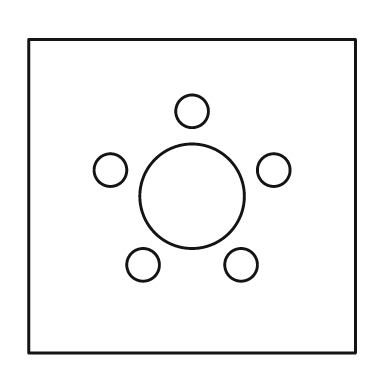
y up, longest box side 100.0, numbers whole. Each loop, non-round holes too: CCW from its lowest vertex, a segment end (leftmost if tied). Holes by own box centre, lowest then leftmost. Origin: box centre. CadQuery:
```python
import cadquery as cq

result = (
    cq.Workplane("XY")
    .moveTo(-50.0, -48.0)
    .lineTo(50.0, -48.0)
    .lineTo(50.0, 48.0)
    .lineTo(-50.0, 48.0)
    .close()
    .moveTo(-15.0, -21.0)
    .circle(5.0)
    .moveTo(15.0, -21.0)
    .circle(5.0)
    .moveTo(0.0, 0.0)
    .circle(16.0)
    .moveTo(-25.0, 8.0)
    .circle(5.0)
    .moveTo(25.0, 8.0)
    .circle(5.0)
    .moveTo(0.0, 26.0)
    .circle(5.0)
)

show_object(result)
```